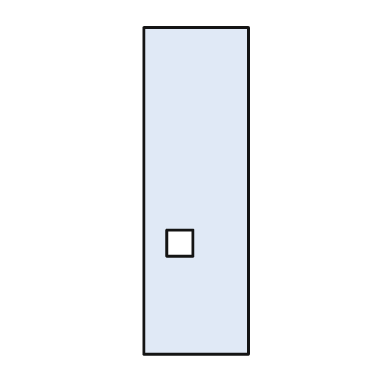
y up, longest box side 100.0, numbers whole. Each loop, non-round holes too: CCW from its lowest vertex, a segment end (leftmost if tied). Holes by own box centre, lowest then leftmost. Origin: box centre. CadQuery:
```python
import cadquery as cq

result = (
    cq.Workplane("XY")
    .moveTo(-16.0, -50.0)
    .lineTo(16.0, -50.0)
    .lineTo(16.0, 50.0)
    .lineTo(-16.0, 50.0)
    .close()
    .moveTo(-9.0, -20.0)
    .lineTo(-1.0, -20.0)
    .lineTo(-1.0, -12.0)
    .lineTo(-9.0, -12.0)
    .close()
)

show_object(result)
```